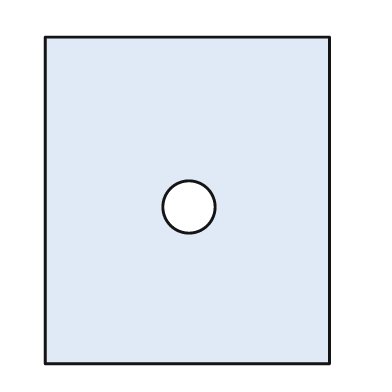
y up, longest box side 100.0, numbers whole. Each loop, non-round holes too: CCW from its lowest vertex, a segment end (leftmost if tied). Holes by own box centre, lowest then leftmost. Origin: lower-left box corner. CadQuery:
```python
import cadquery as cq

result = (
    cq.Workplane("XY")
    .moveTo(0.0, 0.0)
    .lineTo(87.0, 0.0)
    .lineTo(87.0, 100.0)
    .lineTo(0.0, 100.0)
    .close()
    .moveTo(44.0, 48.0)
    .circle(8.0)
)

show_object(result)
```